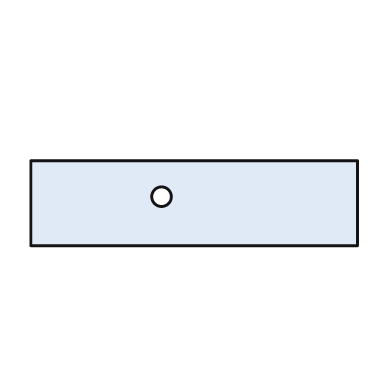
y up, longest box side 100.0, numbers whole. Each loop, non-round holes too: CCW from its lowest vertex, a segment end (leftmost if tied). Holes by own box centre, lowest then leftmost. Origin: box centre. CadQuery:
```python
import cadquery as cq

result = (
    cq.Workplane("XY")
    .moveTo(-50.0, -13.0)
    .lineTo(50.0, -13.0)
    .lineTo(50.0, 13.0)
    .lineTo(-50.0, 13.0)
    .close()
    .moveTo(-10.0, 2.0)
    .circle(3.0)
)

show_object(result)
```